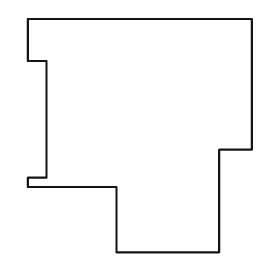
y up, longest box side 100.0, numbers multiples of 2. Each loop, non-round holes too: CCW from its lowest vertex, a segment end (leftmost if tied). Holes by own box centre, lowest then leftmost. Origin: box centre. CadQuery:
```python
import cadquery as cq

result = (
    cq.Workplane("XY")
    .moveTo(-10.0, -50.0)
    .lineTo(34.0, -50.0)
    .lineTo(34.0, -6.0)
    .lineTo(48.0, -6.0)
    .lineTo(48.0, 50.0)
    .lineTo(-48.0, 50.0)
    .lineTo(-48.0, 32.0)
    .lineTo(-40.0, 32.0)
    .lineTo(-40.0, -18.0)
    .lineTo(-48.0, -18.0)
    .lineTo(-48.0, -22.0)
    .lineTo(-10.0, -22.0)
    .close()
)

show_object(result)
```